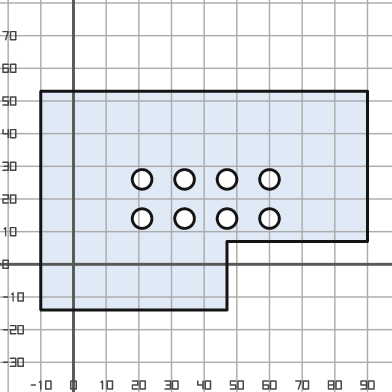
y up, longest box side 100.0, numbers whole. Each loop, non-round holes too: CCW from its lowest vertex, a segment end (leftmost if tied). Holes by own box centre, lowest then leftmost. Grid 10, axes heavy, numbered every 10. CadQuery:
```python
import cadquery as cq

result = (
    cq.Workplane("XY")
    .moveTo(-10.0, -14.0)
    .lineTo(47.0, -14.0)
    .lineTo(47.0, 7.0)
    .lineTo(90.0, 7.0)
    .lineTo(90.0, 53.0)
    .lineTo(-10.0, 53.0)
    .close()
    .moveTo(21.0, 14.0)
    .circle(3.0)
    .moveTo(34.0, 14.0)
    .circle(3.0)
    .moveTo(47.0, 14.0)
    .circle(3.0)
    .moveTo(60.0, 14.0)
    .circle(3.0)
    .moveTo(21.0, 26.0)
    .circle(3.0)
    .moveTo(34.0, 26.0)
    .circle(3.0)
    .moveTo(47.0, 26.0)
    .circle(3.0)
    .moveTo(60.0, 26.0)
    .circle(3.0)
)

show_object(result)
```